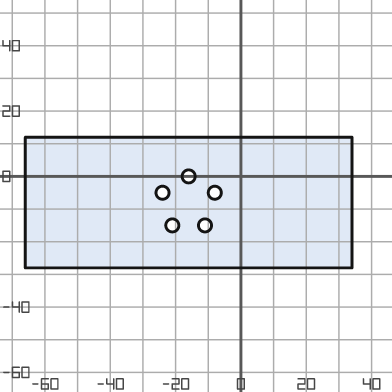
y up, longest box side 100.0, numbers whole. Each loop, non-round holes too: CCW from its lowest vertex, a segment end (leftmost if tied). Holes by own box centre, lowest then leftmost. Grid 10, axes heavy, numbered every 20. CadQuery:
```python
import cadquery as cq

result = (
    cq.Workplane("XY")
    .moveTo(-66.0, -28.0)
    .lineTo(34.0, -28.0)
    .lineTo(34.0, 12.0)
    .lineTo(-66.0, 12.0)
    .close()
    .moveTo(-21.0, -15.0)
    .circle(2.0)
    .moveTo(-11.0, -15.0)
    .circle(2.0)
    .moveTo(-24.0, -5.0)
    .circle(2.0)
    .moveTo(-8.0, -5.0)
    .circle(2.0)
    .moveTo(-16.0, 0.0)
    .circle(2.0)
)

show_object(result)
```